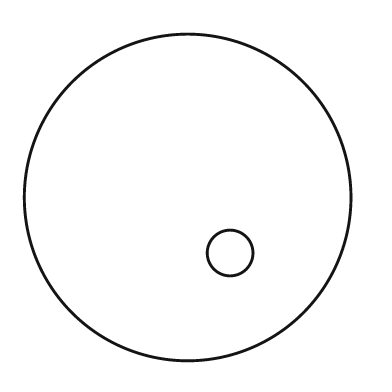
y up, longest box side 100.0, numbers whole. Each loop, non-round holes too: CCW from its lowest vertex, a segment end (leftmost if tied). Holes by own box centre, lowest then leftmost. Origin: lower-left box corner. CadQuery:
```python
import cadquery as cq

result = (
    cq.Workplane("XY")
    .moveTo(50.0, 50.0)
    .circle(50.0)
    .moveTo(63.0, 33.0)
    .circle(7.0)
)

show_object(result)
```